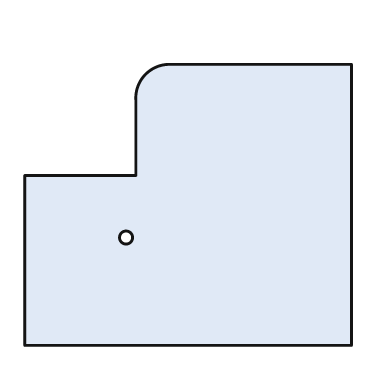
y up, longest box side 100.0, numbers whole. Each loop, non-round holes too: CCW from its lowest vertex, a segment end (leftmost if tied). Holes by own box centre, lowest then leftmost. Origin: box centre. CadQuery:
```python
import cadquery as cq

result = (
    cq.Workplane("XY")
    .moveTo(-50.0, -43.0)
    .lineTo(50.0, -43.0)
    .lineTo(50.0, 43.0)
    .lineTo(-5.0, 43.0)
    .threePointArc((-13.0, 40.0), (-16.0, 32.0))
    .lineTo(-16.0, 9.0)
    .lineTo(-50.0, 9.0)
    .close()
    .moveTo(-19.0, -10.0)
    .circle(2.0)
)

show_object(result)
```